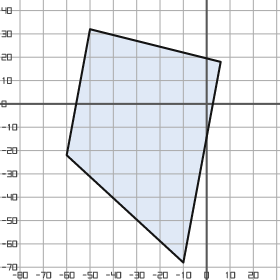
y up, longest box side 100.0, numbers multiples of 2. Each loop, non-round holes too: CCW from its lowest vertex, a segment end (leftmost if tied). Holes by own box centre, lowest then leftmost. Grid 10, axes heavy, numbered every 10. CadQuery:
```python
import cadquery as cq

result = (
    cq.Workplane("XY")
    .moveTo(-10.0, -68.0)
    .lineTo(6.0, 18.0)
    .lineTo(-50.0, 32.0)
    .lineTo(-60.0, -22.0)
    .close()
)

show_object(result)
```